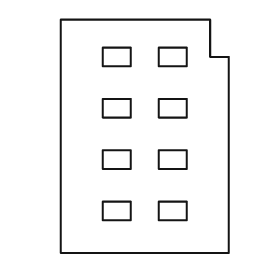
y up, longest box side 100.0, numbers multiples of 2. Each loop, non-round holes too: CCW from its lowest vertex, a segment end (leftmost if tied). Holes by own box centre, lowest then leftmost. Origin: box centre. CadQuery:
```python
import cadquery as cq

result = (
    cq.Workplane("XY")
    .moveTo(-36.0, -50.0)
    .lineTo(36.0, -50.0)
    .lineTo(36.0, 34.0)
    .lineTo(28.0, 34.0)
    .lineTo(28.0, 50.0)
    .lineTo(-36.0, 50.0)
    .close()
    .moveTo(-18.0, -36.0)
    .lineTo(-6.0, -36.0)
    .lineTo(-6.0, -28.0)
    .lineTo(-18.0, -28.0)
    .close()
    .moveTo(6.0, -36.0)
    .lineTo(18.0, -36.0)
    .lineTo(18.0, -28.0)
    .lineTo(6.0, -28.0)
    .close()
    .moveTo(-18.0, -14.0)
    .lineTo(-6.0, -14.0)
    .lineTo(-6.0, -6.0)
    .lineTo(-18.0, -6.0)
    .close()
    .moveTo(6.0, -14.0)
    .lineTo(18.0, -14.0)
    .lineTo(18.0, -6.0)
    .lineTo(6.0, -6.0)
    .close()
    .moveTo(-18.0, 8.0)
    .lineTo(-6.0, 8.0)
    .lineTo(-6.0, 16.0)
    .lineTo(-18.0, 16.0)
    .close()
    .moveTo(6.0, 8.0)
    .lineTo(18.0, 8.0)
    .lineTo(18.0, 16.0)
    .lineTo(6.0, 16.0)
    .close()
    .moveTo(-18.0, 30.0)
    .lineTo(-6.0, 30.0)
    .lineTo(-6.0, 38.0)
    .lineTo(-18.0, 38.0)
    .close()
    .moveTo(6.0, 30.0)
    .lineTo(18.0, 30.0)
    .lineTo(18.0, 38.0)
    .lineTo(6.0, 38.0)
    .close()
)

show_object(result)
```